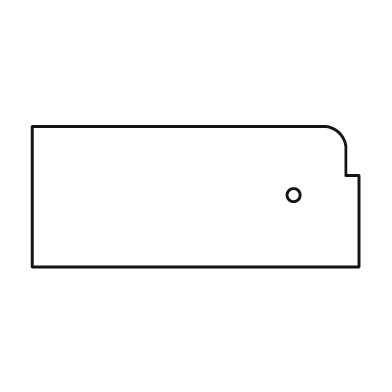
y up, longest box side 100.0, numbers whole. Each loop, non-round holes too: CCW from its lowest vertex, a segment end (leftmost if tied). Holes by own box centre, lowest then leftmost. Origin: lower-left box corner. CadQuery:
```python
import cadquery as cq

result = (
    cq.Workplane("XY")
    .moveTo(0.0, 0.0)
    .lineTo(100.0, 0.0)
    .lineTo(100.0, 28.0)
    .lineTo(96.0, 28.0)
    .lineTo(96.0, 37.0)
    .threePointArc((94.0, 41.0), (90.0, 43.0))
    .lineTo(0.0, 43.0)
    .close()
    .moveTo(80.0, 22.0)
    .circle(2.0)
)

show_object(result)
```